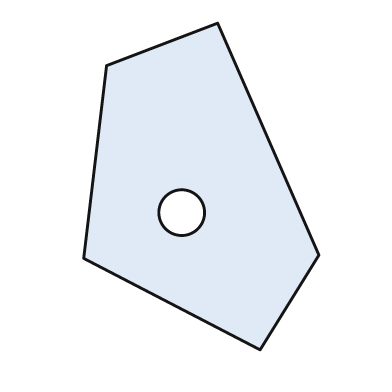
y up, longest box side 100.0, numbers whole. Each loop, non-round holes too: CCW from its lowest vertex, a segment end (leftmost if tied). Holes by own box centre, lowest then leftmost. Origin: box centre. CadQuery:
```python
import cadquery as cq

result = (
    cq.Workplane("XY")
    .moveTo(18.0, -50.0)
    .lineTo(36.0, -21.0)
    .lineTo(5.0, 50.0)
    .lineTo(-29.0, 37.0)
    .lineTo(-36.0, -22.0)
    .close()
    .moveTo(-6.0, -8.0)
    .circle(7.0)
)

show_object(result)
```